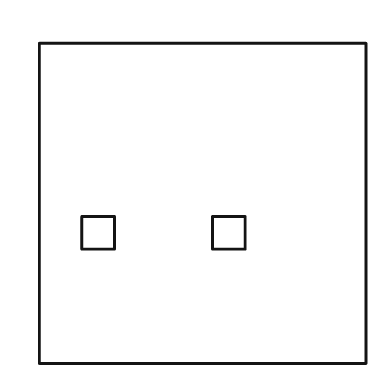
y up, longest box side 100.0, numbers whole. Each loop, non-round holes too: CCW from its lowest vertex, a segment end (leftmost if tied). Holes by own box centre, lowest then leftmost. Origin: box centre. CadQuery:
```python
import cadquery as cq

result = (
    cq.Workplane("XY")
    .moveTo(-50.0, -49.0)
    .lineTo(50.0, -49.0)
    .lineTo(50.0, 49.0)
    .lineTo(-50.0, 49.0)
    .close()
    .moveTo(-37.0, -14.0)
    .lineTo(-27.0, -14.0)
    .lineTo(-27.0, -4.0)
    .lineTo(-37.0, -4.0)
    .close()
    .moveTo(3.0, -14.0)
    .lineTo(13.0, -14.0)
    .lineTo(13.0, -4.0)
    .lineTo(3.0, -4.0)
    .close()
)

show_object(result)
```